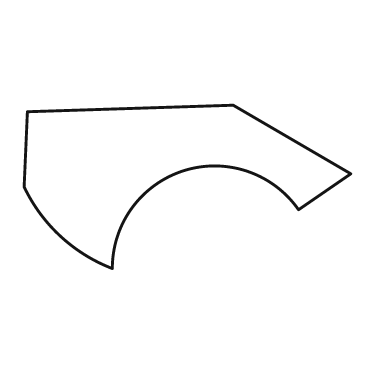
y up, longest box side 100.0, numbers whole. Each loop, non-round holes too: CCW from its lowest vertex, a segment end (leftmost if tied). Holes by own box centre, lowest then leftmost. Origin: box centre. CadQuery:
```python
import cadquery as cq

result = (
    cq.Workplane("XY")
    .moveTo(-23.0, -25.0)
    .threePointArc((-1.0, 5.0), (34.0, -7.0))
    .lineTo(50.0, 4.0)
    .lineTo(14.0, 25.0)
    .lineTo(-49.0, 23.0)
    .lineTo(-50.0, 0.0)
    .threePointArc((-39.0, -15.0), (-23.0, -25.0))
    .close()
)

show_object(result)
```